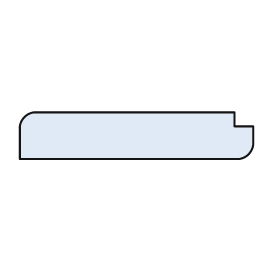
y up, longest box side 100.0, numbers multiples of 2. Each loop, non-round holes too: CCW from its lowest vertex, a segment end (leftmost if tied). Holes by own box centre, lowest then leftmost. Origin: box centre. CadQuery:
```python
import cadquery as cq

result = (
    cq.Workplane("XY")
    .moveTo(-50.0, -10.0)
    .lineTo(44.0, -10.0)
    .threePointArc((48.0, -8.0), (50.0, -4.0))
    .lineTo(50.0, 4.0)
    .lineTo(42.0, 4.0)
    .lineTo(42.0, 10.0)
    .lineTo(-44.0, 10.0)
    .threePointArc((-48.0, 8.0), (-50.0, 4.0))
    .close()
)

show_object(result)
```